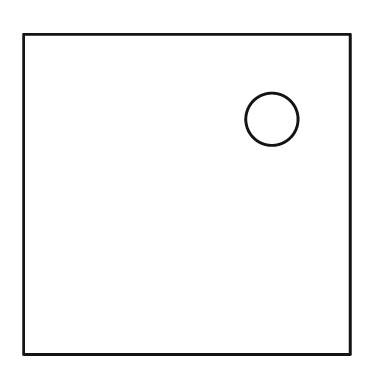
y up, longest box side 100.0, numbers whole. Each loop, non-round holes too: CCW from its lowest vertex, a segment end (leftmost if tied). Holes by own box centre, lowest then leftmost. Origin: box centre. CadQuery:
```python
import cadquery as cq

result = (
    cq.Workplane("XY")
    .moveTo(-50.0, -49.0)
    .lineTo(50.0, -49.0)
    .lineTo(50.0, 49.0)
    .lineTo(-50.0, 49.0)
    .close()
    .moveTo(26.0, 23.0)
    .circle(8.0)
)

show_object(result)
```